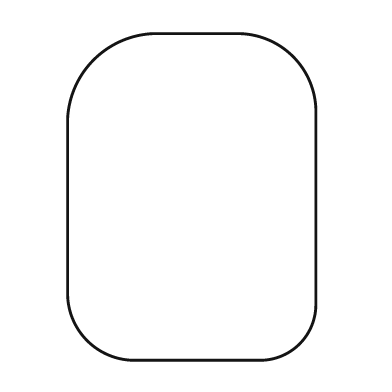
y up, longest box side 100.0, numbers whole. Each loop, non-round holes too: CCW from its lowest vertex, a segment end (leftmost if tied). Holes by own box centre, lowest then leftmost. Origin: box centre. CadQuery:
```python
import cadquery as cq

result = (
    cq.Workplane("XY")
    .moveTo(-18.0, -50.0)
    .lineTo(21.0, -50.0)
    .threePointArc((33.0, -45.0), (38.0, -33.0))
    .lineTo(38.0, 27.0)
    .threePointArc((31.0, 43.0), (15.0, 50.0))
    .lineTo(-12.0, 50.0)
    .threePointArc((-30.0, 42.0), (-38.0, 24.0))
    .lineTo(-38.0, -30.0)
    .threePointArc((-32.0, -44.0), (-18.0, -50.0))
    .close()
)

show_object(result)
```